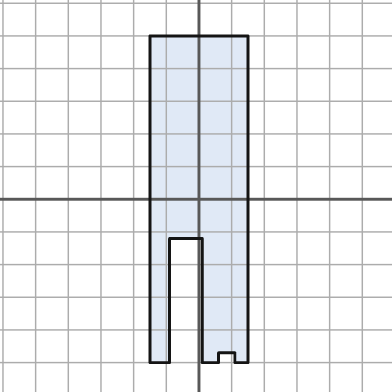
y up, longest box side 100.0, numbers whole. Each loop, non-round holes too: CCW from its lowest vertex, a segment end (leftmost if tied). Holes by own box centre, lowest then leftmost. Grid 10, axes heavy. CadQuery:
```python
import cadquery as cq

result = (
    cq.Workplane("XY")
    .moveTo(-15.0, -50.0)
    .lineTo(-9.0, -50.0)
    .lineTo(-9.0, -12.0)
    .lineTo(1.0, -12.0)
    .lineTo(1.0, -50.0)
    .lineTo(6.0, -50.0)
    .lineTo(6.0, -47.0)
    .lineTo(11.0, -47.0)
    .lineTo(11.0, -50.0)
    .lineTo(15.0, -50.0)
    .lineTo(15.0, 50.0)
    .lineTo(-15.0, 50.0)
    .close()
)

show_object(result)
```